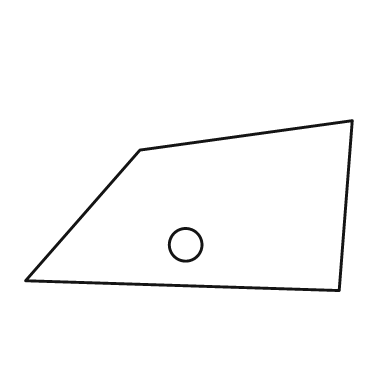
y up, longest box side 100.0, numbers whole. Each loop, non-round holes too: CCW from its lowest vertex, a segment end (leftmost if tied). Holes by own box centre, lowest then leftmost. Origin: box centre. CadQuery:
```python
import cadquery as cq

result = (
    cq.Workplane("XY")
    .moveTo(46.0, -26.0)
    .lineTo(50.0, 26.0)
    .lineTo(-15.0, 17.0)
    .lineTo(-50.0, -23.0)
    .close()
    .moveTo(-1.0, -12.0)
    .circle(5.0)
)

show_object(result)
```